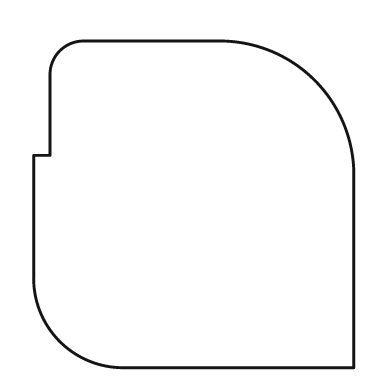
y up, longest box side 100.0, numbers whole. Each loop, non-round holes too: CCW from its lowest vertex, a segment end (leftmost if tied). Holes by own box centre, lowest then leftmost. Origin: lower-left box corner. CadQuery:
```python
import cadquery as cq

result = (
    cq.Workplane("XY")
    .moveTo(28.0, 0.0)
    .lineTo(98.0, 0.0)
    .lineTo(98.0, 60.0)
    .threePointArc((86.0, 88.0), (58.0, 100.0))
    .lineTo(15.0, 100.0)
    .threePointArc((8.0, 97.0), (5.0, 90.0))
    .lineTo(5.0, 65.0)
    .lineTo(0.0, 65.0)
    .lineTo(0.0, 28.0)
    .threePointArc((8.0, 8.0), (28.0, 0.0))
    .close()
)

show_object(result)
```